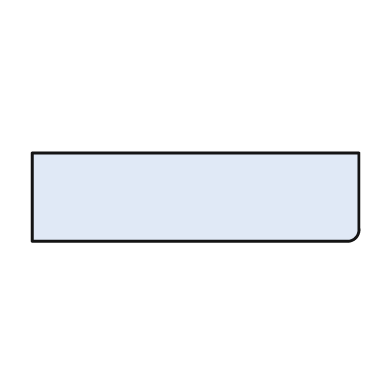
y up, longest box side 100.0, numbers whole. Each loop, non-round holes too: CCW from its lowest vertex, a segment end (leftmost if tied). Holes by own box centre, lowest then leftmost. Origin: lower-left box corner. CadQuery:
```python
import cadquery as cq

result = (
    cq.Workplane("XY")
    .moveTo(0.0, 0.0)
    .lineTo(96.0, 0.0)
    .threePointArc((99.0, 1.0), (100.0, 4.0))
    .lineTo(100.0, 27.0)
    .lineTo(0.0, 27.0)
    .close()
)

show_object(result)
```